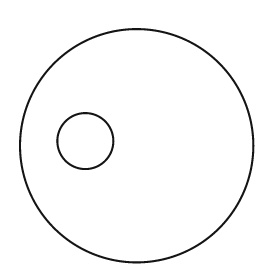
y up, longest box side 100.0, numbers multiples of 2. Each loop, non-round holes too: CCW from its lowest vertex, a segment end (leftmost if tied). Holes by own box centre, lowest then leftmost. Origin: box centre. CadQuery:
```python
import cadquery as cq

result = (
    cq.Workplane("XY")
    .moveTo(0.0, 0.0)
    .circle(50.0)
    .moveTo(-22.0, 2.0)
    .circle(12.0)
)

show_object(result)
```